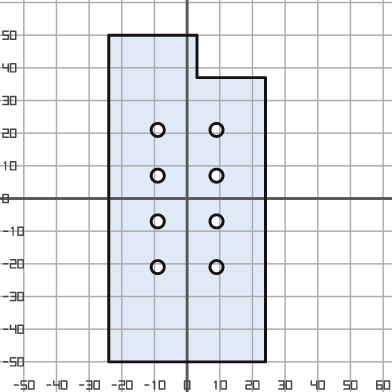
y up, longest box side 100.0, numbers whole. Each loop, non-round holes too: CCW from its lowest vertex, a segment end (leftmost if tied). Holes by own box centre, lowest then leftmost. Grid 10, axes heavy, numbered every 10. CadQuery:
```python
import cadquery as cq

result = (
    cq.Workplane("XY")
    .moveTo(-24.0, -50.0)
    .lineTo(24.0, -50.0)
    .lineTo(24.0, 37.0)
    .lineTo(3.0, 37.0)
    .lineTo(3.0, 50.0)
    .lineTo(-24.0, 50.0)
    .close()
    .moveTo(-9.0, -21.0)
    .circle(2.0)
    .moveTo(9.0, -21.0)
    .circle(2.0)
    .moveTo(-9.0, -7.0)
    .circle(2.0)
    .moveTo(9.0, -7.0)
    .circle(2.0)
    .moveTo(-9.0, 7.0)
    .circle(2.0)
    .moveTo(9.0, 7.0)
    .circle(2.0)
    .moveTo(-9.0, 21.0)
    .circle(2.0)
    .moveTo(9.0, 21.0)
    .circle(2.0)
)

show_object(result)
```